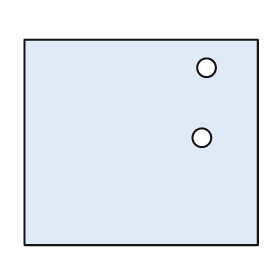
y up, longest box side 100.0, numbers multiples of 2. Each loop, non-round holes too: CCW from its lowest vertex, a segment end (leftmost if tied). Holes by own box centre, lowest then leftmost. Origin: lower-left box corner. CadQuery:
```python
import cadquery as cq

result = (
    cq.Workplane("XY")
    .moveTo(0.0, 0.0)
    .lineTo(100.0, 0.0)
    .lineTo(100.0, 88.0)
    .lineTo(0.0, 88.0)
    .close()
    .moveTo(76.0, 46.0)
    .circle(4.0)
    .moveTo(78.0, 76.0)
    .circle(4.0)
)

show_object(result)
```